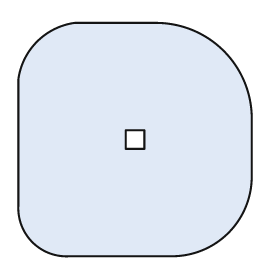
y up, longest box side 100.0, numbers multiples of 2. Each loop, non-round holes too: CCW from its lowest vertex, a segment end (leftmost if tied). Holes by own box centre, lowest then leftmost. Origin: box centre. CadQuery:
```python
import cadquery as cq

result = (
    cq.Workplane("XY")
    .moveTo(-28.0, -50.0)
    .lineTo(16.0, -50.0)
    .threePointArc((40.0, -40.0), (50.0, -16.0))
    .lineTo(50.0, 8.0)
    .threePointArc((38.0, 38.0), (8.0, 50.0))
    .lineTo(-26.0, 50.0)
    .threePointArc((-42.0, 42.0), (-50.0, 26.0))
    .lineTo(-50.0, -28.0)
    .threePointArc((-44.0, -44.0), (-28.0, -50.0))
    .close()
    .moveTo(-4.0, -4.0)
    .lineTo(4.0, -4.0)
    .lineTo(4.0, 4.0)
    .lineTo(-4.0, 4.0)
    .close()
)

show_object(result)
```